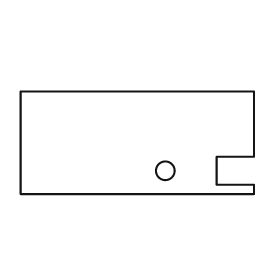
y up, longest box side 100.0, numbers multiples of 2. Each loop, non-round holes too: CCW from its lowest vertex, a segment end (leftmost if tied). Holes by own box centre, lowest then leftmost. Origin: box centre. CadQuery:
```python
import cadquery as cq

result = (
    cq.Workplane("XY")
    .moveTo(-50.0, -22.0)
    .lineTo(50.0, -22.0)
    .lineTo(50.0, -18.0)
    .lineTo(34.0, -18.0)
    .lineTo(34.0, -6.0)
    .lineTo(50.0, -6.0)
    .lineTo(50.0, 22.0)
    .lineTo(-50.0, 22.0)
    .close()
    .moveTo(12.0, -12.0)
    .circle(4.0)
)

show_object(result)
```